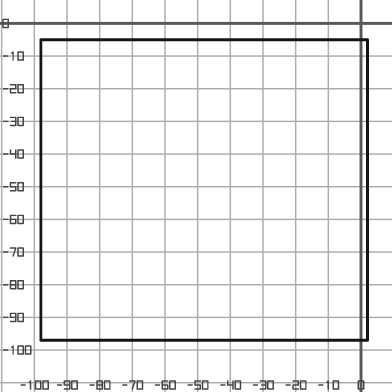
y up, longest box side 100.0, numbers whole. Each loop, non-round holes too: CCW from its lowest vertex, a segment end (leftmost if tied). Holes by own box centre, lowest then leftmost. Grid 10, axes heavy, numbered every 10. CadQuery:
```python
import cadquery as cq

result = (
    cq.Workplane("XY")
    .moveTo(-98.0, -97.0)
    .lineTo(2.0, -97.0)
    .lineTo(2.0, -5.0)
    .lineTo(-98.0, -5.0)
    .close()
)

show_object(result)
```